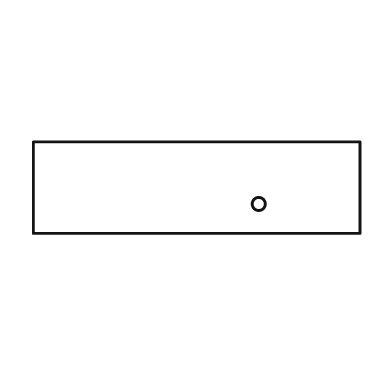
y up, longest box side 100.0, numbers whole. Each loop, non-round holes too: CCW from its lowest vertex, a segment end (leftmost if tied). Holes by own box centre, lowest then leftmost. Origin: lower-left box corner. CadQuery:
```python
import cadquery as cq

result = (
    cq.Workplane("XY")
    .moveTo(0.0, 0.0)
    .lineTo(100.0, 0.0)
    .lineTo(100.0, 28.0)
    .lineTo(0.0, 28.0)
    .close()
    .moveTo(69.0, 9.0)
    .circle(2.0)
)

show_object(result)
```